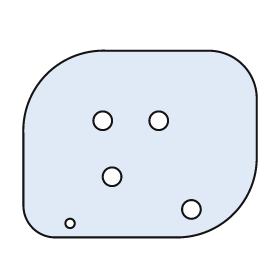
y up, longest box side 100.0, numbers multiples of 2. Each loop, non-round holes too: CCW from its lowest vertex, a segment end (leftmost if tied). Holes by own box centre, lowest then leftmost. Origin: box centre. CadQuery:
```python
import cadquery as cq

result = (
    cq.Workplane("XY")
    .moveTo(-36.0, -40.0)
    .lineTo(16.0, -40.0)
    .threePointArc((40.0, -30.0), (50.0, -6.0))
    .lineTo(50.0, 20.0)
    .threePointArc((44.0, 34.0), (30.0, 40.0))
    .lineTo(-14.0, 40.0)
    .threePointArc((-40.0, 30.0), (-50.0, 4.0))
    .lineTo(-50.0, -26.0)
    .threePointArc((-46.0, -36.0), (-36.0, -40.0))
    .close()
    .moveTo(-30.0, -34.0)
    .circle(2.0)
    .moveTo(22.0, -28.0)
    .circle(4.0)
    .moveTo(-12.0, -14.0)
    .circle(4.0)
    .moveTo(-16.0, 10.0)
    .circle(4.0)
    .moveTo(8.0, 10.0)
    .circle(4.0)
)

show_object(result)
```